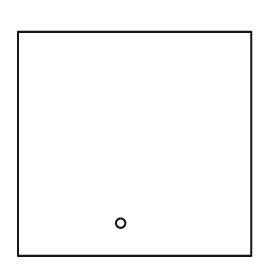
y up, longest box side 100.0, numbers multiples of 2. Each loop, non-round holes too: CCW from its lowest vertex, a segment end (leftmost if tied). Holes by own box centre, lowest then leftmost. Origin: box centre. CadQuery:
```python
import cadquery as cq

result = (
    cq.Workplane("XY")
    .moveTo(-50.0, -48.0)
    .lineTo(50.0, -48.0)
    .lineTo(50.0, 48.0)
    .lineTo(-50.0, 48.0)
    .close()
    .moveTo(-6.0, -34.0)
    .circle(2.0)
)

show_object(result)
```